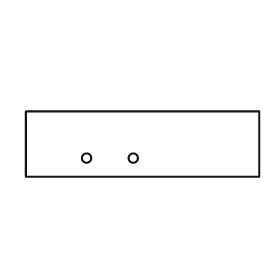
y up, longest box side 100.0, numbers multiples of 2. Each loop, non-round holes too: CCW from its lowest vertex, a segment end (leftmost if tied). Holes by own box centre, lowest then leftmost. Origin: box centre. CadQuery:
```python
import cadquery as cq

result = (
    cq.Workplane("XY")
    .moveTo(-50.0, -14.0)
    .lineTo(50.0, -14.0)
    .lineTo(50.0, 14.0)
    .lineTo(-50.0, 14.0)
    .close()
    .moveTo(-24.0, -6.0)
    .circle(2.0)
    .moveTo(-4.0, -6.0)
    .circle(2.0)
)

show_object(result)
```